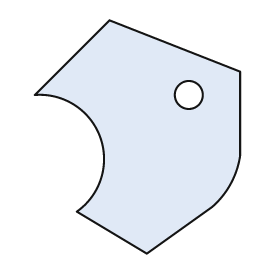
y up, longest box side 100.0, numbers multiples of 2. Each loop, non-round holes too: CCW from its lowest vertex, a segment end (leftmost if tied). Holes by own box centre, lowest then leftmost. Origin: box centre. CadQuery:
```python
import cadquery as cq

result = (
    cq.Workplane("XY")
    .moveTo(4.0, -50.0)
    .lineTo(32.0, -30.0)
    .threePointArc((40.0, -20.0), (44.0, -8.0))
    .lineTo(44.0, 28.0)
    .lineTo(-12.0, 50.0)
    .lineTo(-44.0, 18.0)
    .threePointArc((-16.0, 0.0), (-26.0, -32.0))
    .close()
    .moveTo(22.0, 18.0)
    .circle(6.0)
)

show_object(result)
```